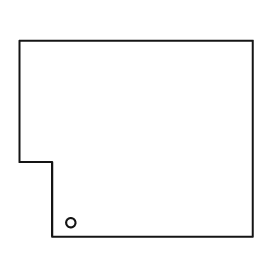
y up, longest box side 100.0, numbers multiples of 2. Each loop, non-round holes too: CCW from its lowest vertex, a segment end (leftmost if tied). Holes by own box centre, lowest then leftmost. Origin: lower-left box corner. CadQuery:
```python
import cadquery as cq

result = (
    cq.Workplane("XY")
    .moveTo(14.0, 0.0)
    .lineTo(100.0, 0.0)
    .lineTo(100.0, 84.0)
    .lineTo(0.0, 84.0)
    .lineTo(0.0, 32.0)
    .lineTo(14.0, 32.0)
    .close()
    .moveTo(22.0, 6.0)
    .circle(2.0)
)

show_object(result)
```